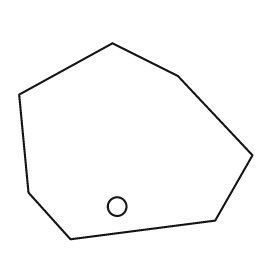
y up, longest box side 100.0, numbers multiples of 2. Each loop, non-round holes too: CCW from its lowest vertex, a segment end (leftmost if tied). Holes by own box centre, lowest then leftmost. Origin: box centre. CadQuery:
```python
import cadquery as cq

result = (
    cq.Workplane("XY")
    .moveTo(-28.0, -42.0)
    .lineTo(34.0, -34.0)
    .lineTo(50.0, -6.0)
    .lineTo(18.0, 28.0)
    .lineTo(-10.0, 42.0)
    .lineTo(-50.0, 20.0)
    .lineTo(-46.0, -22.0)
    .close()
    .moveTo(-8.0, -28.0)
    .circle(4.0)
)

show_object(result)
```